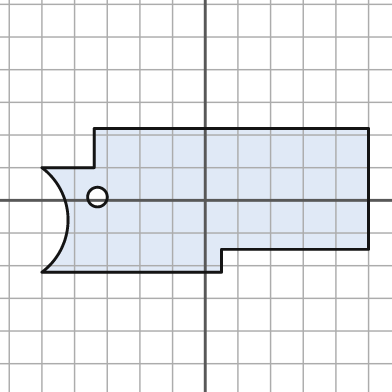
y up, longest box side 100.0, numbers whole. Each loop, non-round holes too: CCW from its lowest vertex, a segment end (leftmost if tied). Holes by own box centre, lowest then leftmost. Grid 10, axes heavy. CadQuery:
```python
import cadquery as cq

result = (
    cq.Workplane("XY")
    .moveTo(-50.0, -22.0)
    .lineTo(5.0, -22.0)
    .lineTo(5.0, -15.0)
    .lineTo(50.0, -15.0)
    .lineTo(50.0, 22.0)
    .lineTo(-34.0, 22.0)
    .lineTo(-34.0, 10.0)
    .lineTo(-50.0, 10.0)
    .threePointArc((-42.0, -6.0), (-50.0, -22.0))
    .close()
    .moveTo(-33.0, 1.0)
    .circle(3.0)
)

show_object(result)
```